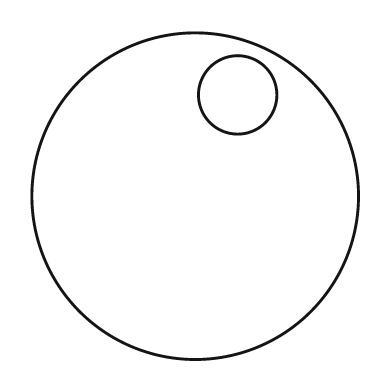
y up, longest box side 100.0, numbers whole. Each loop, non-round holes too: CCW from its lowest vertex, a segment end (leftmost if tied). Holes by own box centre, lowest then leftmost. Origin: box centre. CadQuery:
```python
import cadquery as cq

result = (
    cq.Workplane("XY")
    .moveTo(0.0, 0.0)
    .circle(50.0)
    .moveTo(13.0, 31.0)
    .circle(12.0)
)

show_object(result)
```